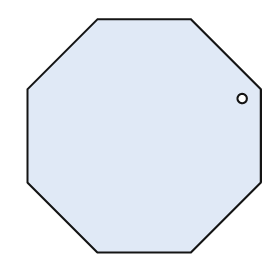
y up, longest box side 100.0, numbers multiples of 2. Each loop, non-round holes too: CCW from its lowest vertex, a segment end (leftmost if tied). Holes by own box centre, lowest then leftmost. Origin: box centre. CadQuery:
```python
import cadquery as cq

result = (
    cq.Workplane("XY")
    .moveTo(-20.0, -50.0)
    .lineTo(20.0, -50.0)
    .lineTo(50.0, -20.0)
    .lineTo(50.0, 20.0)
    .lineTo(20.0, 50.0)
    .lineTo(-20.0, 50.0)
    .lineTo(-50.0, 20.0)
    .lineTo(-50.0, -20.0)
    .close()
    .moveTo(42.0, 16.0)
    .circle(2.0)
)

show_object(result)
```